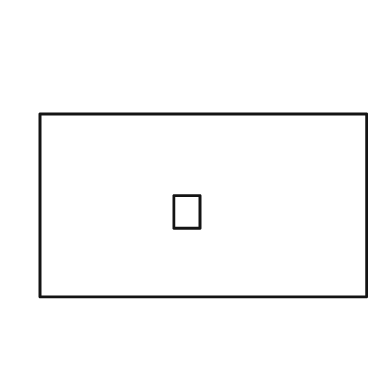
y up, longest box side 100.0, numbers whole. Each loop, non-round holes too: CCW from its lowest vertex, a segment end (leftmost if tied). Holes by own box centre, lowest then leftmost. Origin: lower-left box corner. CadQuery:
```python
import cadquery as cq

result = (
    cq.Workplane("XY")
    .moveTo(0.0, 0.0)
    .lineTo(100.0, 0.0)
    .lineTo(100.0, 56.0)
    .lineTo(0.0, 56.0)
    .close()
    .moveTo(41.0, 21.0)
    .lineTo(49.0, 21.0)
    .lineTo(49.0, 31.0)
    .lineTo(41.0, 31.0)
    .close()
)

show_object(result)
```